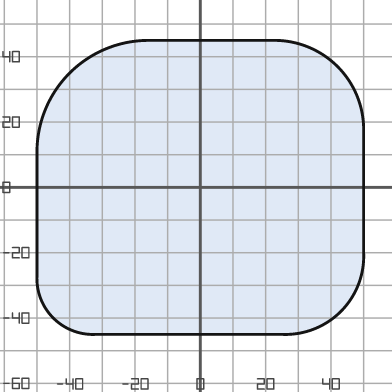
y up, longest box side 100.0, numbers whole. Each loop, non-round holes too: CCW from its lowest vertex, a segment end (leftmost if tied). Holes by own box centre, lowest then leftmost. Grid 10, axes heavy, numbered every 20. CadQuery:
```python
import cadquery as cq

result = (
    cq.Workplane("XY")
    .moveTo(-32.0, -45.0)
    .lineTo(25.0, -45.0)
    .threePointArc((43.0, -38.0), (50.0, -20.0))
    .lineTo(50.0, 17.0)
    .threePointArc((42.0, 37.0), (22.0, 45.0))
    .lineTo(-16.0, 45.0)
    .threePointArc((-40.0, 35.0), (-50.0, 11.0))
    .lineTo(-50.0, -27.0)
    .threePointArc((-45.0, -40.0), (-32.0, -45.0))
    .close()
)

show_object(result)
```